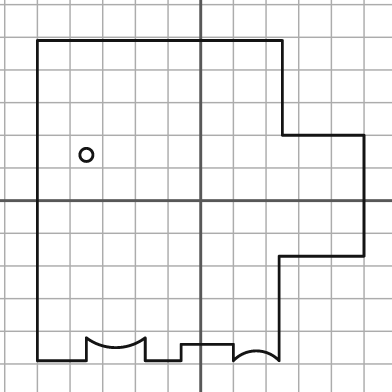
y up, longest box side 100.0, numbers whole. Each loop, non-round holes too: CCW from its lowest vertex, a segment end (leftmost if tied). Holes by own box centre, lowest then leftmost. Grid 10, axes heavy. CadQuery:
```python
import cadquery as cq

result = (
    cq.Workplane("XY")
    .moveTo(-50.0, -49.0)
    .lineTo(-35.0, -49.0)
    .lineTo(-35.0, -42.0)
    .threePointArc((-26.0, -45.0), (-17.0, -42.0))
    .lineTo(-17.0, -49.0)
    .lineTo(-6.0, -49.0)
    .lineTo(-6.0, -44.0)
    .lineTo(10.0, -44.0)
    .lineTo(10.0, -49.0)
    .threePointArc((17.0, -46.0), (24.0, -49.0))
    .lineTo(24.0, -17.0)
    .lineTo(50.0, -17.0)
    .lineTo(50.0, 20.0)
    .lineTo(25.0, 20.0)
    .lineTo(25.0, 49.0)
    .lineTo(-50.0, 49.0)
    .close()
    .moveTo(-35.0, 14.0)
    .circle(2.0)
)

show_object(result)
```